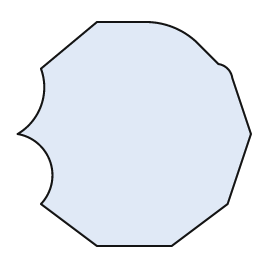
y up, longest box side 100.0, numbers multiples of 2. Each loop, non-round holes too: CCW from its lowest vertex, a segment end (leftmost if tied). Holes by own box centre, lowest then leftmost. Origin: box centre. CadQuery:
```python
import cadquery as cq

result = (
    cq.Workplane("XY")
    .moveTo(-16.0, -48.0)
    .lineTo(16.0, -48.0)
    .lineTo(40.0, -30.0)
    .lineTo(50.0, 0.0)
    .lineTo(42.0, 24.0)
    .threePointArc((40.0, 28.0), (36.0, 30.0))
    .lineTo(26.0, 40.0)
    .threePointArc((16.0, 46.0), (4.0, 48.0))
    .lineTo(-16.0, 48.0)
    .lineTo(-40.0, 28.0)
    .threePointArc((-40.0, 12.0), (-50.0, 0.0))
    .threePointArc((-36.0, -12.0), (-40.0, -30.0))
    .close()
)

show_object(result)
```